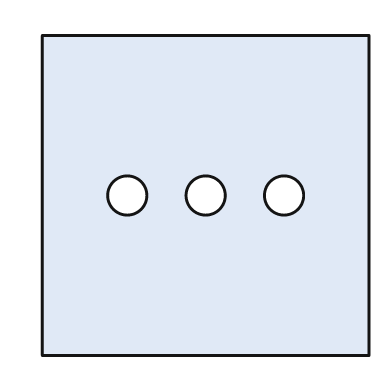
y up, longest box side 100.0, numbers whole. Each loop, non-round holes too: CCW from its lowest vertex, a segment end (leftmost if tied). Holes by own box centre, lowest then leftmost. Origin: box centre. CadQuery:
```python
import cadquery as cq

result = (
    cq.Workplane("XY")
    .moveTo(-50.0, -49.0)
    .lineTo(50.0, -49.0)
    .lineTo(50.0, 49.0)
    .lineTo(-50.0, 49.0)
    .close()
    .moveTo(-24.0, 0.0)
    .circle(6.0)
    .moveTo(0.0, 0.0)
    .circle(6.0)
    .moveTo(24.0, 0.0)
    .circle(6.0)
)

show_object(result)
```